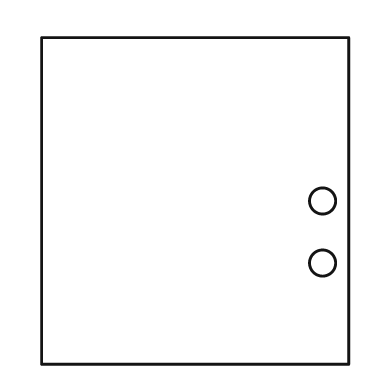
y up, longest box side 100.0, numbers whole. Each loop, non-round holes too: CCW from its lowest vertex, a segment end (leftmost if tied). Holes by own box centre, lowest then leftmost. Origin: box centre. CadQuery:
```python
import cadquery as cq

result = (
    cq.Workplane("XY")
    .moveTo(-47.0, -50.0)
    .lineTo(47.0, -50.0)
    .lineTo(47.0, 50.0)
    .lineTo(-47.0, 50.0)
    .close()
    .moveTo(39.0, -19.0)
    .circle(4.0)
    .moveTo(39.0, 0.0)
    .circle(4.0)
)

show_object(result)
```